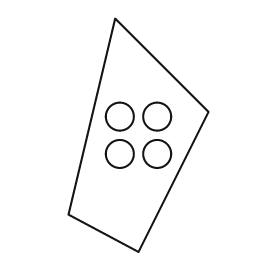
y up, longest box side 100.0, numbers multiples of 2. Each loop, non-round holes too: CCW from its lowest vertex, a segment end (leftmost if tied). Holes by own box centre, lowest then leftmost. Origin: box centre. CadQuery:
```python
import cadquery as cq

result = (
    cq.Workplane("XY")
    .moveTo(0.0, -50.0)
    .lineTo(30.0, 10.0)
    .lineTo(-10.0, 50.0)
    .lineTo(-30.0, -34.0)
    .close()
    .moveTo(-8.0, -8.0)
    .circle(6.0)
    .moveTo(8.0, -8.0)
    .circle(6.0)
    .moveTo(-8.0, 8.0)
    .circle(6.0)
    .moveTo(8.0, 8.0)
    .circle(6.0)
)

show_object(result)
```